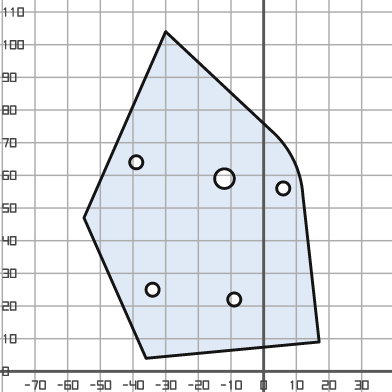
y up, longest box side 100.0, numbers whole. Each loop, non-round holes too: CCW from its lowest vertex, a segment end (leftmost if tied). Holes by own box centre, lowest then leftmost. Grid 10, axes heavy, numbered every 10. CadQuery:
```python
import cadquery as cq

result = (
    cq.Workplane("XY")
    .moveTo(-36.0, 4.0)
    .lineTo(17.0, 9.0)
    .lineTo(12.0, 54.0)
    .threePointArc((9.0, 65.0), (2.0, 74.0))
    .lineTo(-30.0, 104.0)
    .lineTo(-55.0, 47.0)
    .close()
    .moveTo(-9.0, 22.0)
    .circle(2.0)
    .moveTo(-34.0, 25.0)
    .circle(2.0)
    .moveTo(6.0, 56.0)
    .circle(2.0)
    .moveTo(-12.0, 59.0)
    .circle(3.0)
    .moveTo(-39.0, 64.0)
    .circle(2.0)
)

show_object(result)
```